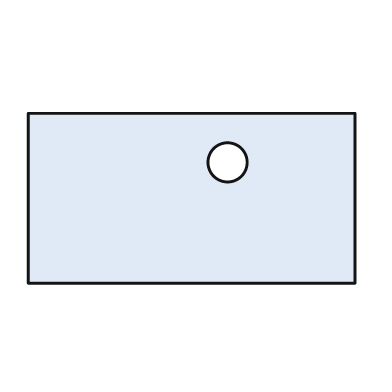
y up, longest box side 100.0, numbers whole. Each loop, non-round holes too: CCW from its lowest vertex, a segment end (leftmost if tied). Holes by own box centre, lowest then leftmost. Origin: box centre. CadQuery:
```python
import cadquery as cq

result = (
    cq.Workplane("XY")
    .moveTo(-50.0, -26.0)
    .lineTo(50.0, -26.0)
    .lineTo(50.0, 26.0)
    .lineTo(-50.0, 26.0)
    .close()
    .moveTo(11.0, 11.0)
    .circle(6.0)
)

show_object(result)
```